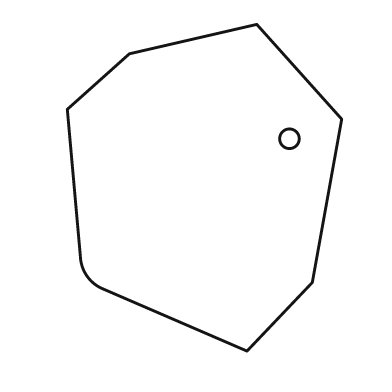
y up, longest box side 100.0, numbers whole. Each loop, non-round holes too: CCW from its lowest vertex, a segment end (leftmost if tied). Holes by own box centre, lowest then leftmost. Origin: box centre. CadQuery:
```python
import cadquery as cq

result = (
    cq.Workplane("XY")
    .moveTo(13.0, -50.0)
    .lineTo(33.0, -29.0)
    .lineTo(42.0, 21.0)
    .lineTo(16.0, 50.0)
    .lineTo(-23.0, 41.0)
    .lineTo(-42.0, 24.0)
    .lineTo(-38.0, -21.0)
    .threePointArc((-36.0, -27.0), (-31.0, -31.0))
    .close()
    .moveTo(26.0, 15.0)
    .circle(3.0)
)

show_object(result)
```